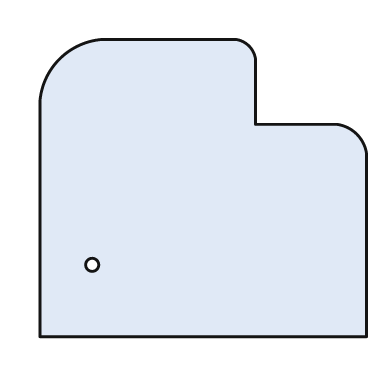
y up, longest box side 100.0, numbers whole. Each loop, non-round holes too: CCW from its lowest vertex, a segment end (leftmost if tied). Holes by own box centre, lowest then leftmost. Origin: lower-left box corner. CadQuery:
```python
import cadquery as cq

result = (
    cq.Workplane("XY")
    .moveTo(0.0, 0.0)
    .lineTo(100.0, 0.0)
    .lineTo(100.0, 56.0)
    .threePointArc((97.0, 62.0), (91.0, 65.0))
    .lineTo(66.0, 65.0)
    .lineTo(66.0, 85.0)
    .threePointArc((64.0, 89.0), (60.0, 91.0))
    .lineTo(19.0, 91.0)
    .threePointArc((6.0, 85.0), (0.0, 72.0))
    .close()
    .moveTo(16.0, 22.0)
    .circle(2.0)
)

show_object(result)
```